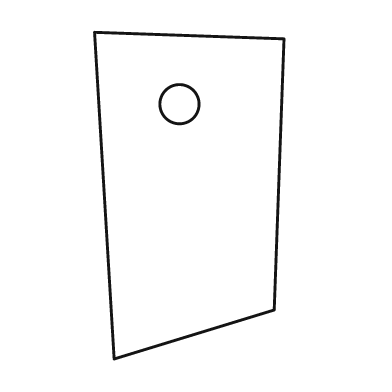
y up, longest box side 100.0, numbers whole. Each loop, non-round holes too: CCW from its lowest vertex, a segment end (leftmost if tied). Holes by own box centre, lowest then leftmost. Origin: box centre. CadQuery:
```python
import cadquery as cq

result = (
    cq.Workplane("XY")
    .moveTo(-23.0, -50.0)
    .lineTo(26.0, -35.0)
    .lineTo(29.0, 48.0)
    .lineTo(-29.0, 50.0)
    .close()
    .moveTo(-3.0, 28.0)
    .circle(6.0)
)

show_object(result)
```